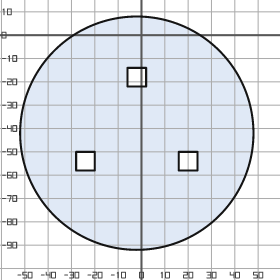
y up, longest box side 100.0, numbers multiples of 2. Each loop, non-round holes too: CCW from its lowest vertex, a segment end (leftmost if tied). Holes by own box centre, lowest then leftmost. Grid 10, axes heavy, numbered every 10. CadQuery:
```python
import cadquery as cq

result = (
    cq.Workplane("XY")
    .moveTo(-2.0, -42.0)
    .circle(50.0)
    .moveTo(-28.0, -58.0)
    .lineTo(-20.0, -58.0)
    .lineTo(-20.0, -50.0)
    .lineTo(-28.0, -50.0)
    .close()
    .moveTo(16.0, -58.0)
    .lineTo(24.0, -58.0)
    .lineTo(24.0, -50.0)
    .lineTo(16.0, -50.0)
    .close()
    .moveTo(-6.0, -22.0)
    .lineTo(2.0, -22.0)
    .lineTo(2.0, -14.0)
    .lineTo(-6.0, -14.0)
    .close()
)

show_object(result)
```